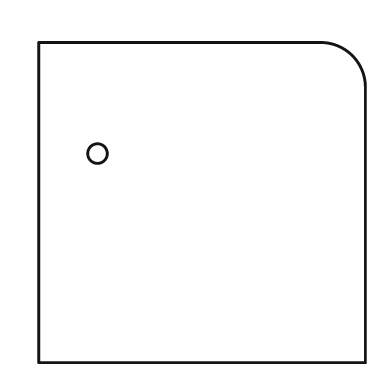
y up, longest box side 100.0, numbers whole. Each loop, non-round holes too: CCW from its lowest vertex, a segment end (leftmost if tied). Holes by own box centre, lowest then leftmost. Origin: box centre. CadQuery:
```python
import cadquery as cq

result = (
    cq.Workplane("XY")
    .moveTo(-50.0, -49.0)
    .lineTo(50.0, -49.0)
    .lineTo(50.0, 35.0)
    .threePointArc((46.0, 45.0), (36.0, 49.0))
    .lineTo(-50.0, 49.0)
    .close()
    .moveTo(-32.0, 15.0)
    .circle(3.0)
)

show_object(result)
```